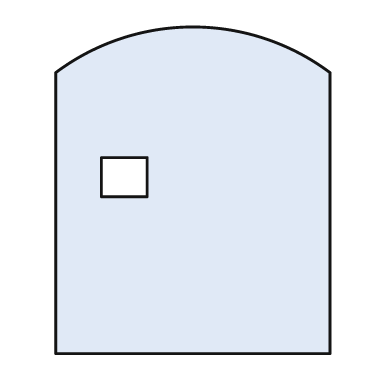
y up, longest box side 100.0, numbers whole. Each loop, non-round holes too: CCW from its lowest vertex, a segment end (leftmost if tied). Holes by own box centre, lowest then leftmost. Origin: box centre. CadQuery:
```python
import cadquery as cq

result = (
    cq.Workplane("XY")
    .moveTo(-42.0, -50.0)
    .lineTo(42.0, -50.0)
    .lineTo(42.0, 36.0)
    .threePointArc((0.0, 50.0), (-42.0, 36.0))
    .close()
    .moveTo(-28.0, -2.0)
    .lineTo(-14.0, -2.0)
    .lineTo(-14.0, 10.0)
    .lineTo(-28.0, 10.0)
    .close()
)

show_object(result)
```